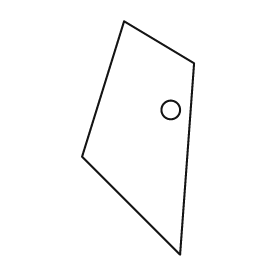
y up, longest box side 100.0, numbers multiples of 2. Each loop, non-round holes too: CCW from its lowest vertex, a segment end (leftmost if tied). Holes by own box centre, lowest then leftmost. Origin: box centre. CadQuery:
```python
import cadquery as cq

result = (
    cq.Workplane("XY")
    .moveTo(18.0, -50.0)
    .lineTo(24.0, 32.0)
    .lineTo(-6.0, 50.0)
    .lineTo(-24.0, -8.0)
    .close()
    .moveTo(14.0, 12.0)
    .circle(4.0)
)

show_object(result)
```